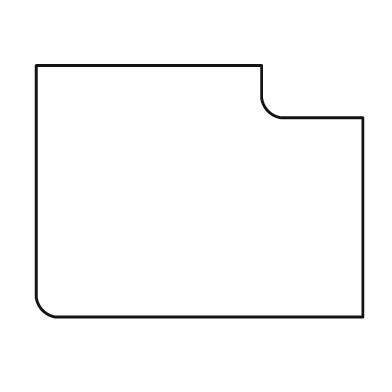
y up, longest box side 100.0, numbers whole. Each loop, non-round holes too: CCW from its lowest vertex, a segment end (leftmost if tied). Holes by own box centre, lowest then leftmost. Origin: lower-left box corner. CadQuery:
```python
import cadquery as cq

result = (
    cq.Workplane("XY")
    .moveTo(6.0, 0.0)
    .lineTo(100.0, 0.0)
    .lineTo(100.0, 61.0)
    .lineTo(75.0, 61.0)
    .threePointArc((71.0, 63.0), (69.0, 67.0))
    .lineTo(69.0, 77.0)
    .lineTo(0.0, 77.0)
    .lineTo(0.0, 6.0)
    .threePointArc((2.0, 2.0), (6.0, 0.0))
    .close()
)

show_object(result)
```